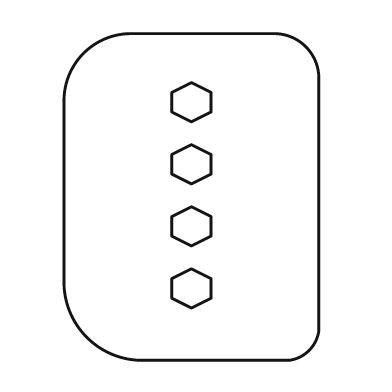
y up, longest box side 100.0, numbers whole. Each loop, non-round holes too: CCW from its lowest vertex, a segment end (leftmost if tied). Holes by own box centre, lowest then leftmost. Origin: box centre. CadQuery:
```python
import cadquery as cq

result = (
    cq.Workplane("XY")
    .moveTo(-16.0, -50.0)
    .lineTo(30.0, -50.0)
    .threePointArc((36.0, -47.0), (39.0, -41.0))
    .lineTo(39.0, 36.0)
    .threePointArc((35.0, 46.0), (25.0, 50.0))
    .lineTo(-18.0, 50.0)
    .threePointArc((-33.0, 44.0), (-39.0, 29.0))
    .lineTo(-39.0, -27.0)
    .threePointArc((-32.0, -43.0), (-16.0, -50.0))
    .close()
    .moveTo(0.0, -34.0)
    .lineTo(6.0, -31.0)
    .lineTo(6.0, -25.0)
    .lineTo(0.0, -22.0)
    .lineTo(-6.0, -25.0)
    .lineTo(-6.0, -31.0)
    .close()
    .moveTo(0.0, -15.0)
    .lineTo(6.0, -12.0)
    .lineTo(6.0, -6.0)
    .lineTo(0.0, -3.0)
    .lineTo(-6.0, -6.0)
    .lineTo(-6.0, -12.0)
    .close()
    .moveTo(0.0, 4.0)
    .lineTo(6.0, 7.0)
    .lineTo(6.0, 13.0)
    .lineTo(0.0, 16.0)
    .lineTo(-6.0, 13.0)
    .lineTo(-6.0, 7.0)
    .close()
    .moveTo(0.0, 23.0)
    .lineTo(6.0, 26.0)
    .lineTo(6.0, 32.0)
    .lineTo(0.0, 35.0)
    .lineTo(-6.0, 32.0)
    .lineTo(-6.0, 26.0)
    .close()
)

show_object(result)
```